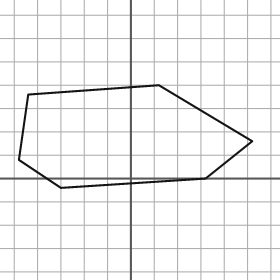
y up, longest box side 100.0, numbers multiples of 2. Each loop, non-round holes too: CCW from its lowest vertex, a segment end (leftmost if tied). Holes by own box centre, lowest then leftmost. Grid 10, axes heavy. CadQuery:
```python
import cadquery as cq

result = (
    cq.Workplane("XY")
    .moveTo(-30.0, -4.0)
    .lineTo(32.0, 0.0)
    .lineTo(52.0, 16.0)
    .lineTo(12.0, 40.0)
    .lineTo(-44.0, 36.0)
    .lineTo(-48.0, 8.0)
    .close()
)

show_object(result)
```